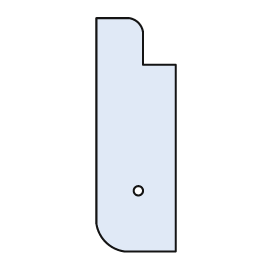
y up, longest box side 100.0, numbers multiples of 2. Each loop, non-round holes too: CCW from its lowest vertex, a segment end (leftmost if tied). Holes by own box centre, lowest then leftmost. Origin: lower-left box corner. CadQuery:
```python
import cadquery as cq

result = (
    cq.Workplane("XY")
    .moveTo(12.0, 0.0)
    .lineTo(34.0, 0.0)
    .lineTo(34.0, 80.0)
    .lineTo(20.0, 80.0)
    .lineTo(20.0, 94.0)
    .threePointArc((18.0, 98.0), (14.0, 100.0))
    .lineTo(0.0, 100.0)
    .lineTo(0.0, 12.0)
    .threePointArc((4.0, 4.0), (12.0, 0.0))
    .close()
    .moveTo(18.0, 26.0)
    .circle(2.0)
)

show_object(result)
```